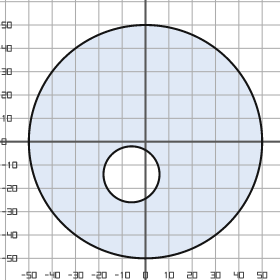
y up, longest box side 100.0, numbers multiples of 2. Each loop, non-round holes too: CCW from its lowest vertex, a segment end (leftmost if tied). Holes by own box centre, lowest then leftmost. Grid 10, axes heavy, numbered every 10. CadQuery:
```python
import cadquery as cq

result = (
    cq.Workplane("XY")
    .moveTo(0.0, 0.0)
    .circle(50.0)
    .moveTo(-6.0, -14.0)
    .circle(12.0)
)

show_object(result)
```